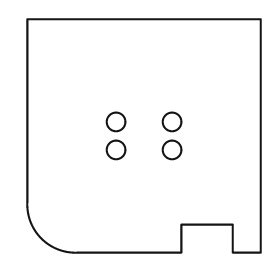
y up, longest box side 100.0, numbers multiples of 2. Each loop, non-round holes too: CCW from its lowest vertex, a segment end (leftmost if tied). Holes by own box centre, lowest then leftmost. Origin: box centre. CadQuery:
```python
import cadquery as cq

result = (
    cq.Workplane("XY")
    .moveTo(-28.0, -50.0)
    .lineTo(16.0, -50.0)
    .lineTo(16.0, -38.0)
    .lineTo(38.0, -38.0)
    .lineTo(38.0, -50.0)
    .lineTo(50.0, -50.0)
    .lineTo(50.0, 50.0)
    .lineTo(-50.0, 50.0)
    .lineTo(-50.0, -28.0)
    .threePointArc((-44.0, -44.0), (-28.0, -50.0))
    .close()
    .moveTo(-12.0, -6.0)
    .circle(4.0)
    .moveTo(12.0, -6.0)
    .circle(4.0)
    .moveTo(-12.0, 6.0)
    .circle(4.0)
    .moveTo(12.0, 6.0)
    .circle(4.0)
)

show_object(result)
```